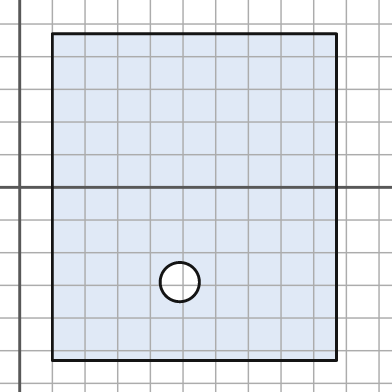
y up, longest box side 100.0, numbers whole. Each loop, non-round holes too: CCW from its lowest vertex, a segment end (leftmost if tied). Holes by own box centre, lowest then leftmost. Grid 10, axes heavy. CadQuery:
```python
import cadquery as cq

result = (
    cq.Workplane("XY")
    .moveTo(10.0, -53.0)
    .lineTo(97.0, -53.0)
    .lineTo(97.0, 47.0)
    .lineTo(10.0, 47.0)
    .close()
    .moveTo(49.0, -29.0)
    .circle(6.0)
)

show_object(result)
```